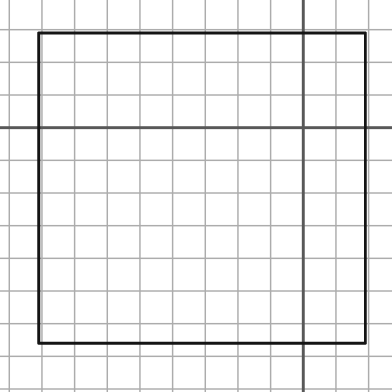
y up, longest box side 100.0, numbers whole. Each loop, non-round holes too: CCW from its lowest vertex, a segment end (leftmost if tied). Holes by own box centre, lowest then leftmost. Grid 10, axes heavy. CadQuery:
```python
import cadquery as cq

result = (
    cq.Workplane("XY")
    .moveTo(-81.0, -66.0)
    .lineTo(19.0, -66.0)
    .lineTo(19.0, 29.0)
    .lineTo(-81.0, 29.0)
    .close()
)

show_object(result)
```